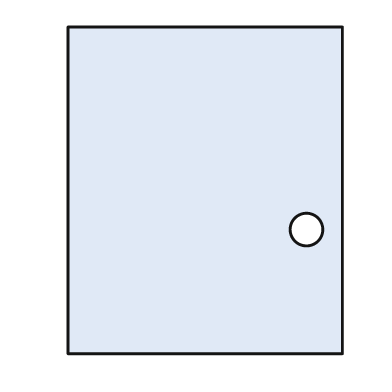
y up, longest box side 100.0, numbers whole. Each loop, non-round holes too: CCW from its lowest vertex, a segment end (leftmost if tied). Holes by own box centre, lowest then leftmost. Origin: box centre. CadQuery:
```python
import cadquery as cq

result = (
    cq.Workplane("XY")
    .moveTo(-42.0, -50.0)
    .lineTo(42.0, -50.0)
    .lineTo(42.0, 50.0)
    .lineTo(-42.0, 50.0)
    .close()
    .moveTo(31.0, -12.0)
    .circle(5.0)
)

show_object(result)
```